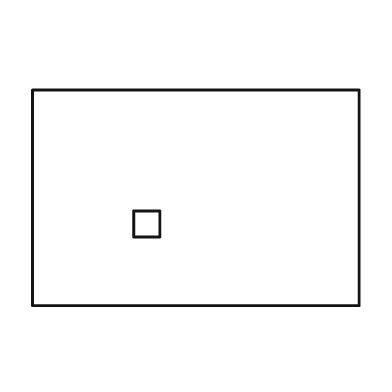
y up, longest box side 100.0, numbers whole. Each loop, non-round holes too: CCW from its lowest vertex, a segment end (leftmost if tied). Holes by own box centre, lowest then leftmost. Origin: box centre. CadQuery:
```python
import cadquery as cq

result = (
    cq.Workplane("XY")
    .moveTo(-50.0, -33.0)
    .lineTo(50.0, -33.0)
    .lineTo(50.0, 33.0)
    .lineTo(-50.0, 33.0)
    .close()
    .moveTo(-19.0, -12.0)
    .lineTo(-11.0, -12.0)
    .lineTo(-11.0, -4.0)
    .lineTo(-19.0, -4.0)
    .close()
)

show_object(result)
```